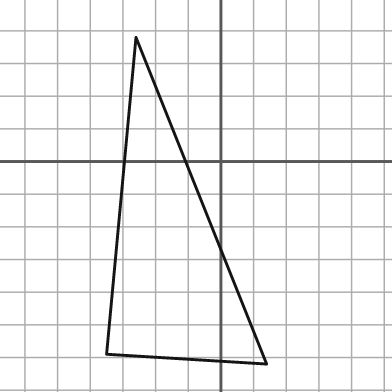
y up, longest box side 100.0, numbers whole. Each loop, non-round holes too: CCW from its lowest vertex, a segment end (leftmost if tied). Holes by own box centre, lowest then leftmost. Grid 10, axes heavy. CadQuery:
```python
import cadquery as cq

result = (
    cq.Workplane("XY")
    .moveTo(14.0, -62.0)
    .lineTo(-26.0, 38.0)
    .lineTo(-35.0, -59.0)
    .close()
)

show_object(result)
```